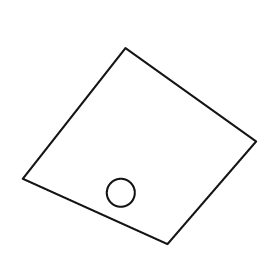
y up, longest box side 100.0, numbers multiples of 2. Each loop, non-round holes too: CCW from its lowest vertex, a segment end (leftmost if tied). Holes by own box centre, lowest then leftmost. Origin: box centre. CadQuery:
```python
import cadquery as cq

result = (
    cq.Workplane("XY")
    .moveTo(12.0, -42.0)
    .lineTo(50.0, 2.0)
    .lineTo(-6.0, 42.0)
    .lineTo(-50.0, -14.0)
    .close()
    .moveTo(-8.0, -20.0)
    .circle(6.0)
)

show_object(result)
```